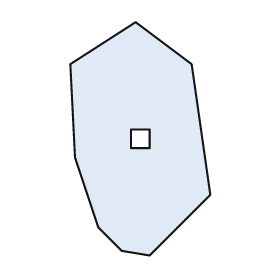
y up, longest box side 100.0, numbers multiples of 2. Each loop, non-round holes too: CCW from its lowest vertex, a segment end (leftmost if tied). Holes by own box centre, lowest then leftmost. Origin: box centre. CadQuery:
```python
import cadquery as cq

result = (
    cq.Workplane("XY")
    .moveTo(4.0, -50.0)
    .lineTo(30.0, -24.0)
    .lineTo(22.0, 32.0)
    .lineTo(-2.0, 50.0)
    .lineTo(-30.0, 32.0)
    .lineTo(-28.0, -8.0)
    .lineTo(-18.0, -38.0)
    .lineTo(-8.0, -48.0)
    .close()
    .moveTo(-4.0, -4.0)
    .lineTo(4.0, -4.0)
    .lineTo(4.0, 4.0)
    .lineTo(-4.0, 4.0)
    .close()
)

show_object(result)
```